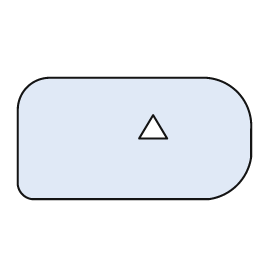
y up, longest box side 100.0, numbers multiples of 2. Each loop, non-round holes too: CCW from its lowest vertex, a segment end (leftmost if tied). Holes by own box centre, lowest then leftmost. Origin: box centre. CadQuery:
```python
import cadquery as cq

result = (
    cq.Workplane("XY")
    .moveTo(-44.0, -26.0)
    .lineTo(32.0, -26.0)
    .threePointArc((44.0, -20.0), (50.0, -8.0))
    .lineTo(50.0, 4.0)
    .threePointArc((44.0, 20.0), (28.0, 26.0))
    .lineTo(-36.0, 26.0)
    .threePointArc((-46.0, 22.0), (-50.0, 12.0))
    .lineTo(-50.0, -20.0)
    .threePointArc((-48.0, -24.0), (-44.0, -26.0))
    .close()
    .moveTo(2.0, 0.0)
    .lineTo(14.0, 0.0)
    .lineTo(8.0, 10.0)
    .close()
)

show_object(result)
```